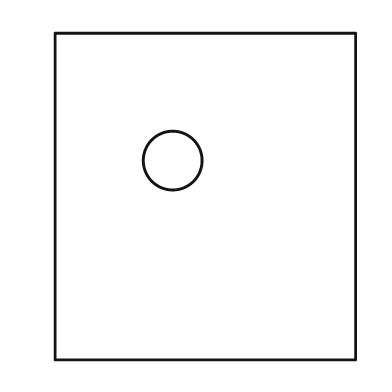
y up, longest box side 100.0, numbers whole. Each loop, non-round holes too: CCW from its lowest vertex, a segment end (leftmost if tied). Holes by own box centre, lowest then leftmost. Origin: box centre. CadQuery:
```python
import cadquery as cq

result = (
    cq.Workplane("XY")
    .moveTo(-46.0, -50.0)
    .lineTo(46.0, -50.0)
    .lineTo(46.0, 50.0)
    .lineTo(-46.0, 50.0)
    .close()
    .moveTo(-10.0, 11.0)
    .circle(9.0)
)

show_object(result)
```